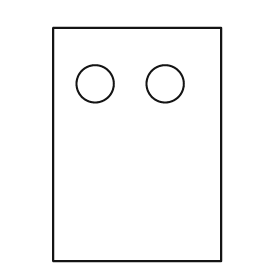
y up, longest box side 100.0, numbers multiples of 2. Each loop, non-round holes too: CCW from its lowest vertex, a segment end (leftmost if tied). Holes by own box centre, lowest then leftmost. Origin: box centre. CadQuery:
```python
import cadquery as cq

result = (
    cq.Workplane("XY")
    .moveTo(-36.0, -50.0)
    .lineTo(36.0, -50.0)
    .lineTo(36.0, 50.0)
    .lineTo(-36.0, 50.0)
    .close()
    .moveTo(-18.0, 26.0)
    .circle(8.0)
    .moveTo(12.0, 26.0)
    .circle(8.0)
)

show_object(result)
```